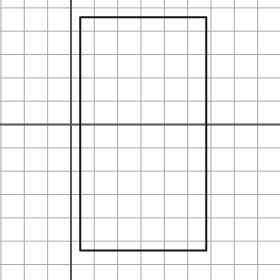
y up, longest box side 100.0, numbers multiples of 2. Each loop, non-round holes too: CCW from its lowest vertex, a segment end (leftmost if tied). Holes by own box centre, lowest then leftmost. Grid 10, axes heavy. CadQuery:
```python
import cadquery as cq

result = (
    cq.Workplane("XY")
    .moveTo(4.0, -54.0)
    .lineTo(58.0, -54.0)
    .lineTo(58.0, 46.0)
    .lineTo(4.0, 46.0)
    .close()
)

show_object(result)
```